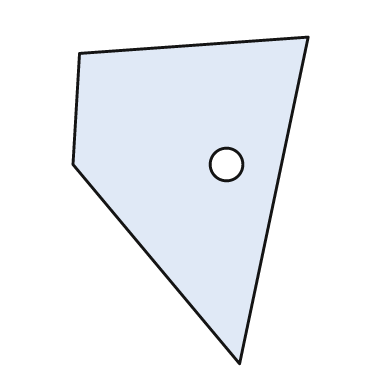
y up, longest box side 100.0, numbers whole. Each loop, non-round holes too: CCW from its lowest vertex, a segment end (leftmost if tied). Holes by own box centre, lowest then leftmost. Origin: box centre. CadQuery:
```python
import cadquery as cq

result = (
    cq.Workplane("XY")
    .moveTo(15.0, -50.0)
    .lineTo(36.0, 50.0)
    .lineTo(-34.0, 45.0)
    .lineTo(-36.0, 11.0)
    .close()
    .moveTo(11.0, 11.0)
    .circle(5.0)
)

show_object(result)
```